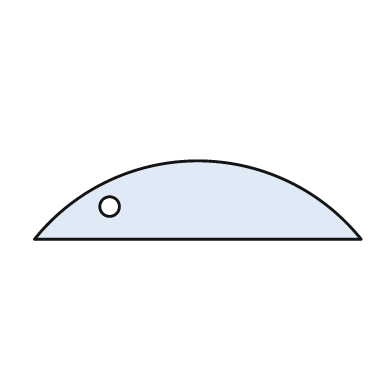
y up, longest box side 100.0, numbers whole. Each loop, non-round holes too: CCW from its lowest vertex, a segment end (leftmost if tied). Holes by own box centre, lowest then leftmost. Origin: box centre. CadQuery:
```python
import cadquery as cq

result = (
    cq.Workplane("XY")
    .moveTo(-50.0, -12.0)
    .lineTo(50.0, -12.0)
    .threePointArc((0.0, 12.0), (-50.0, -12.0))
    .close()
    .moveTo(-27.0, -2.0)
    .circle(3.0)
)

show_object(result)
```